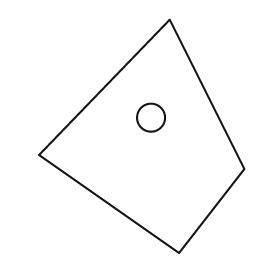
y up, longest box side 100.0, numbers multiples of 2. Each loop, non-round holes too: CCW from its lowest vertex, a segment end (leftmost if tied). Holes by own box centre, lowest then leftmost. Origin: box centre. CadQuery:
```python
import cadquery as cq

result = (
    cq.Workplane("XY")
    .moveTo(16.0, -50.0)
    .lineTo(44.0, -14.0)
    .lineTo(12.0, 50.0)
    .lineTo(-44.0, -8.0)
    .close()
    .moveTo(4.0, 8.0)
    .circle(6.0)
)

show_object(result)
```